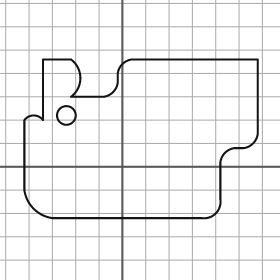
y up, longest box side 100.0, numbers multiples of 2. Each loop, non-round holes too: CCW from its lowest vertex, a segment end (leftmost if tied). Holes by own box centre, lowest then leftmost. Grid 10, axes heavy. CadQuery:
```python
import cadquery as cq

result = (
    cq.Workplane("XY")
    .moveTo(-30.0, -22.0)
    .lineTo(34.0, -22.0)
    .threePointArc((40.0, -20.0), (42.0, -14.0))
    .lineTo(42.0, 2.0)
    .threePointArc((44.0, 6.0), (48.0, 8.0))
    .lineTo(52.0, 8.0)
    .threePointArc((56.0, 10.0), (58.0, 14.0))
    .lineTo(58.0, 46.0)
    .lineTo(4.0, 46.0)
    .threePointArc((0.0, 44.0), (-2.0, 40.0))
    .lineTo(-2.0, 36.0)
    .threePointArc((-4.0, 32.0), (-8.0, 30.0))
    .lineTo(-22.0, 30.0)
    .threePointArc((-18.0, 38.0), (-22.0, 46.0))
    .lineTo(-34.0, 46.0)
    .lineTo(-34.0, 20.0)
    .threePointArc((-38.0, 22.0), (-42.0, 20.0))
    .lineTo(-42.0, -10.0)
    .threePointArc((-38.0, -18.0), (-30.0, -22.0))
    .close()
    .moveTo(-24.0, 22.0)
    .circle(4.0)
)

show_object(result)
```